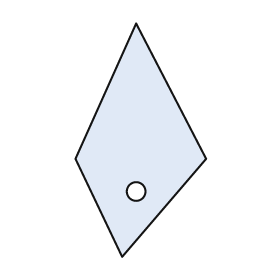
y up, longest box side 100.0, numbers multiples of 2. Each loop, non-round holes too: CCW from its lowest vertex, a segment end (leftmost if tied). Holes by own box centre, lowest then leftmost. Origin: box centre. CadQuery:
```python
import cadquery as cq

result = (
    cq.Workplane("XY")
    .moveTo(-8.0, -50.0)
    .lineTo(28.0, -8.0)
    .lineTo(-2.0, 50.0)
    .lineTo(-28.0, -8.0)
    .close()
    .moveTo(-2.0, -22.0)
    .circle(4.0)
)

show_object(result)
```